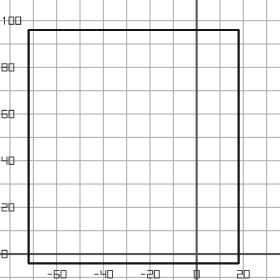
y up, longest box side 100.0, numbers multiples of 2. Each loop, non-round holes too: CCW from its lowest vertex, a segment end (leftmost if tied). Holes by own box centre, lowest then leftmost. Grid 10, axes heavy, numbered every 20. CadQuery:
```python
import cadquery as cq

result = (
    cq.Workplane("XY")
    .moveTo(-72.0, -4.0)
    .lineTo(18.0, -4.0)
    .lineTo(18.0, 96.0)
    .lineTo(-72.0, 96.0)
    .close()
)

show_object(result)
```